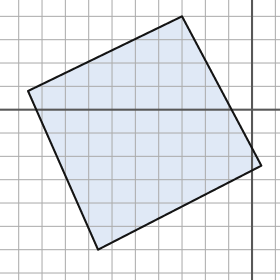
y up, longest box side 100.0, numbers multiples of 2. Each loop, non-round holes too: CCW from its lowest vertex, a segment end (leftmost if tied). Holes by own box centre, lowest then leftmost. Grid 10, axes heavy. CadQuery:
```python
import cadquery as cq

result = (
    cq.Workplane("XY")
    .moveTo(-66.0, -60.0)
    .lineTo(4.0, -24.0)
    .lineTo(-30.0, 40.0)
    .lineTo(-96.0, 8.0)
    .close()
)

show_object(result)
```